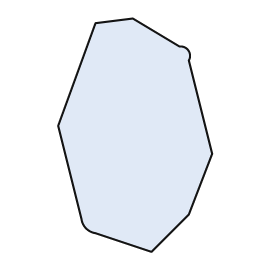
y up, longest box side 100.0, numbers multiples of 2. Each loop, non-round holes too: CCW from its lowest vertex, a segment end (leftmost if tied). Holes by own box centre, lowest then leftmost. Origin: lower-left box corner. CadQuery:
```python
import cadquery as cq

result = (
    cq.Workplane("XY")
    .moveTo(40.0, 0.0)
    .lineTo(56.0, 16.0)
    .lineTo(66.0, 42.0)
    .lineTo(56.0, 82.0)
    .threePointArc((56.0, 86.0), (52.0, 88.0))
    .lineTo(32.0, 100.0)
    .lineTo(16.0, 98.0)
    .lineTo(0.0, 54.0)
    .lineTo(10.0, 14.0)
    .threePointArc((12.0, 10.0), (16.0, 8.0))
    .close()
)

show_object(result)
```